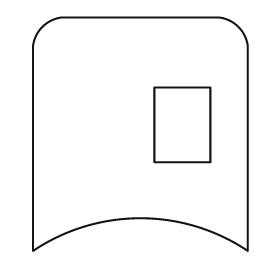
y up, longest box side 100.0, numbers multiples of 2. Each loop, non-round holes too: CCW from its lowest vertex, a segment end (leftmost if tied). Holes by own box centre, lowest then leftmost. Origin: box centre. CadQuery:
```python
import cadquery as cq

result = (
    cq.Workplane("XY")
    .moveTo(-46.0, -50.0)
    .threePointArc((0.0, -36.0), (46.0, -50.0))
    .lineTo(46.0, 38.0)
    .threePointArc((42.0, 46.0), (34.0, 50.0))
    .lineTo(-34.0, 50.0)
    .threePointArc((-42.0, 46.0), (-46.0, 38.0))
    .close()
    .moveTo(6.0, -12.0)
    .lineTo(30.0, -12.0)
    .lineTo(30.0, 20.0)
    .lineTo(6.0, 20.0)
    .close()
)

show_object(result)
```